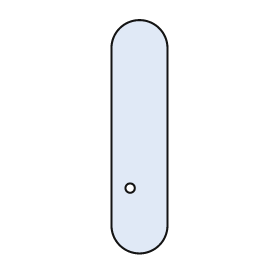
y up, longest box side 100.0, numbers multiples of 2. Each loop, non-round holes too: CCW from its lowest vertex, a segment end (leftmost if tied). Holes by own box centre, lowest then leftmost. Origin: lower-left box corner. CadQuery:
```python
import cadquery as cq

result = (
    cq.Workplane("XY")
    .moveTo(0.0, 12.0)
    .threePointArc((12.0, 0.0), (24.0, 12.0))
    .lineTo(24.0, 88.0)
    .threePointArc((12.0, 100.0), (0.0, 88.0))
    .close()
    .moveTo(8.0, 28.0)
    .circle(2.0)
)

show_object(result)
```